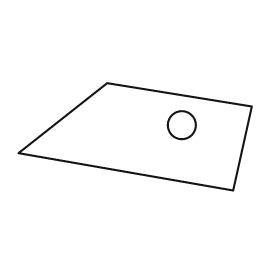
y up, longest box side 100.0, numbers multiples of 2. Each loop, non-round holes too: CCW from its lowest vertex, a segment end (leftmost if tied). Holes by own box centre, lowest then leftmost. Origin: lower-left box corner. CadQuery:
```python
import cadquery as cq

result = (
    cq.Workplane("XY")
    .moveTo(92.0, 0.0)
    .lineTo(100.0, 36.0)
    .lineTo(38.0, 46.0)
    .lineTo(0.0, 16.0)
    .close()
    .moveTo(70.0, 28.0)
    .circle(6.0)
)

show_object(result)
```